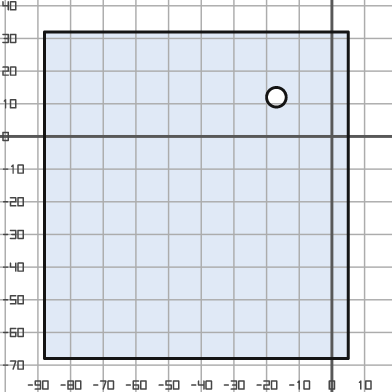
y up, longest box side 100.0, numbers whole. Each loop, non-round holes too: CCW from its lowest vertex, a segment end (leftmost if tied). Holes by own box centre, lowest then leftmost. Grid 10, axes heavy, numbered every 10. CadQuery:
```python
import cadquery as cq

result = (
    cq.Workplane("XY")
    .moveTo(-88.0, -68.0)
    .lineTo(5.0, -68.0)
    .lineTo(5.0, 32.0)
    .lineTo(-88.0, 32.0)
    .close()
    .moveTo(-17.0, 12.0)
    .circle(3.0)
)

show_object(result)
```